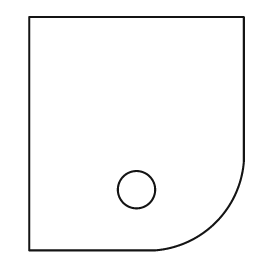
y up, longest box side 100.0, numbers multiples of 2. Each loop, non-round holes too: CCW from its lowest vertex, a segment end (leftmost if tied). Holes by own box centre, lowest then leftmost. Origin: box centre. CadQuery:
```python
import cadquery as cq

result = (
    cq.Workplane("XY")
    .moveTo(-46.0, -50.0)
    .lineTo(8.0, -50.0)
    .threePointArc((34.0, -38.0), (46.0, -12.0))
    .lineTo(46.0, 50.0)
    .lineTo(-46.0, 50.0)
    .close()
    .moveTo(0.0, -24.0)
    .circle(8.0)
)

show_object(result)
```